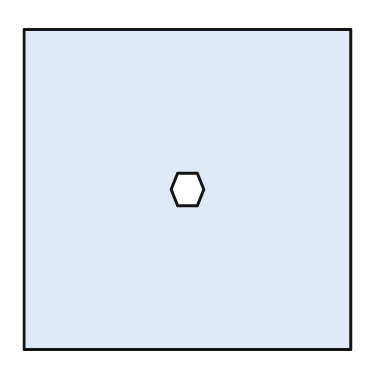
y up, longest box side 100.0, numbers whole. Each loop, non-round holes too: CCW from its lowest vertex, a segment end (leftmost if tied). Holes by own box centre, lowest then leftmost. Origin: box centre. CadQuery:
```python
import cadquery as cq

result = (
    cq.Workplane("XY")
    .moveTo(-50.0, -49.0)
    .lineTo(50.0, -49.0)
    .lineTo(50.0, 49.0)
    .lineTo(-50.0, 49.0)
    .close()
    .moveTo(-3.0, -5.0)
    .lineTo(3.0, -5.0)
    .lineTo(5.0, 0.0)
    .lineTo(3.0, 5.0)
    .lineTo(-3.0, 5.0)
    .lineTo(-5.0, 0.0)
    .close()
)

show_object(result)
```